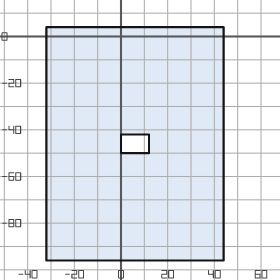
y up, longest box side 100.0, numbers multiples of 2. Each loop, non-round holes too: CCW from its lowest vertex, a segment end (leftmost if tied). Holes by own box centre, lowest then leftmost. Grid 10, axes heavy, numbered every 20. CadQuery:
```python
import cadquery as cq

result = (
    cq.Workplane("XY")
    .moveTo(-32.0, -96.0)
    .lineTo(44.0, -96.0)
    .lineTo(44.0, 4.0)
    .lineTo(-32.0, 4.0)
    .close()
    .moveTo(0.0, -50.0)
    .lineTo(12.0, -50.0)
    .lineTo(12.0, -42.0)
    .lineTo(0.0, -42.0)
    .close()
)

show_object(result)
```